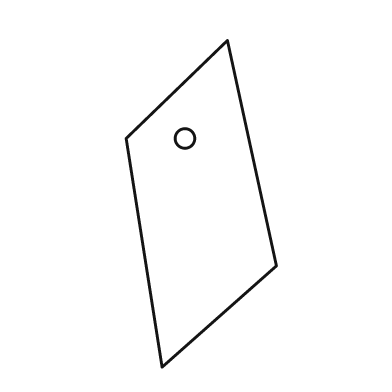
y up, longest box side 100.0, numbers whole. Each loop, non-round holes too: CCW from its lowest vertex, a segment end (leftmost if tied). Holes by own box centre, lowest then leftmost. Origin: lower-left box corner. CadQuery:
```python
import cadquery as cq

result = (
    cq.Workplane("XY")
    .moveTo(11.0, 0.0)
    .lineTo(46.0, 31.0)
    .lineTo(31.0, 100.0)
    .lineTo(0.0, 70.0)
    .close()
    .moveTo(18.0, 70.0)
    .circle(3.0)
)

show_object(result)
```